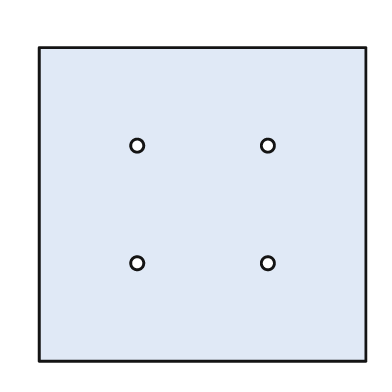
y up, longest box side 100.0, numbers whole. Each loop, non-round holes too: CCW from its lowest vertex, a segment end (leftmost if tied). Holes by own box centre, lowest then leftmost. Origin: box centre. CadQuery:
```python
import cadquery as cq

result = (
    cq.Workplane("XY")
    .moveTo(-50.0, -48.0)
    .lineTo(50.0, -48.0)
    .lineTo(50.0, 48.0)
    .lineTo(-50.0, 48.0)
    .close()
    .moveTo(-20.0, -18.0)
    .circle(2.0)
    .moveTo(20.0, -18.0)
    .circle(2.0)
    .moveTo(-20.0, 18.0)
    .circle(2.0)
    .moveTo(20.0, 18.0)
    .circle(2.0)
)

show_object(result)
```